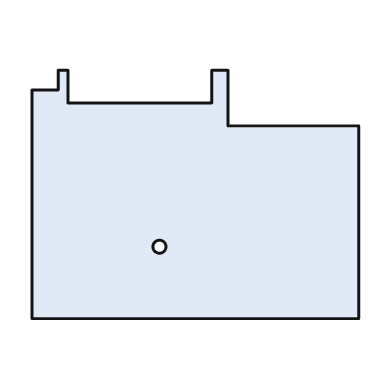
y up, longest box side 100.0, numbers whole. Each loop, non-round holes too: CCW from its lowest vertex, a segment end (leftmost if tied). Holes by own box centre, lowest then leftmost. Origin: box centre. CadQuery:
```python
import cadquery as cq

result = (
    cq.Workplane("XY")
    .moveTo(-50.0, -38.0)
    .lineTo(50.0, -38.0)
    .lineTo(50.0, 21.0)
    .lineTo(10.0, 21.0)
    .lineTo(10.0, 38.0)
    .lineTo(5.0, 38.0)
    .lineTo(5.0, 28.0)
    .lineTo(-39.0, 28.0)
    .lineTo(-39.0, 38.0)
    .lineTo(-42.0, 38.0)
    .lineTo(-42.0, 32.0)
    .lineTo(-50.0, 32.0)
    .close()
    .moveTo(-11.0, -16.0)
    .circle(2.0)
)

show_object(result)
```